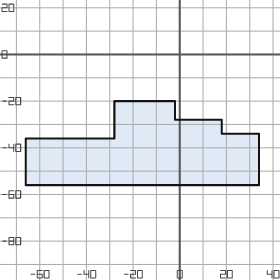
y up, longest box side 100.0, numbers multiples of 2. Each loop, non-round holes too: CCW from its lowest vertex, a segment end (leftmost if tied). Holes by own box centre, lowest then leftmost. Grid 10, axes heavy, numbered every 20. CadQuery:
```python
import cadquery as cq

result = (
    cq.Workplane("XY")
    .moveTo(-66.0, -56.0)
    .lineTo(34.0, -56.0)
    .lineTo(34.0, -34.0)
    .lineTo(18.0, -34.0)
    .lineTo(18.0, -28.0)
    .lineTo(-2.0, -28.0)
    .lineTo(-2.0, -20.0)
    .lineTo(-28.0, -20.0)
    .lineTo(-28.0, -36.0)
    .lineTo(-66.0, -36.0)
    .close()
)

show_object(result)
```